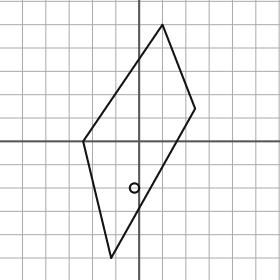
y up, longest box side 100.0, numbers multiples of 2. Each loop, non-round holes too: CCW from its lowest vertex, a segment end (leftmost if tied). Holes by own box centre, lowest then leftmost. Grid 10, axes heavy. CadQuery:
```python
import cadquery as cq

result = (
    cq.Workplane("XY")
    .moveTo(-12.0, -50.0)
    .lineTo(24.0, 14.0)
    .lineTo(10.0, 50.0)
    .lineTo(-24.0, 0.0)
    .close()
    .moveTo(-2.0, -20.0)
    .circle(2.0)
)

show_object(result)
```